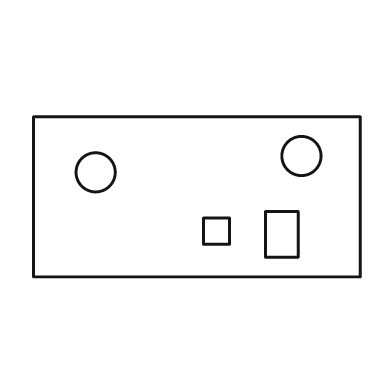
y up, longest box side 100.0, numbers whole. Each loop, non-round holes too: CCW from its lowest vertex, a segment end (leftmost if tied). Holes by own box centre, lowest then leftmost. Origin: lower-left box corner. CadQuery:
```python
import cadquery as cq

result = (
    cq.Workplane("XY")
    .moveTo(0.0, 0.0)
    .lineTo(100.0, 0.0)
    .lineTo(100.0, 49.0)
    .lineTo(0.0, 49.0)
    .close()
    .moveTo(71.0, 6.0)
    .lineTo(81.0, 6.0)
    .lineTo(81.0, 20.0)
    .lineTo(71.0, 20.0)
    .close()
    .moveTo(52.0, 10.0)
    .lineTo(60.0, 10.0)
    .lineTo(60.0, 18.0)
    .lineTo(52.0, 18.0)
    .close()
    .moveTo(19.0, 32.0)
    .circle(6.0)
    .moveTo(82.0, 37.0)
    .circle(6.0)
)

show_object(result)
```